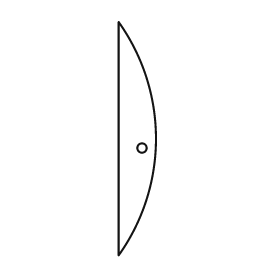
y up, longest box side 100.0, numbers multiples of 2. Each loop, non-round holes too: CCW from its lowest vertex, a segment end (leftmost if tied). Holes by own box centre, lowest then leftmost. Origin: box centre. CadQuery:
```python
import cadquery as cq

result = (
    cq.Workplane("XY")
    .moveTo(-8.0, -50.0)
    .threePointArc((8.0, 0.0), (-8.0, 50.0))
    .close()
    .moveTo(2.0, -4.0)
    .circle(2.0)
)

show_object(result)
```